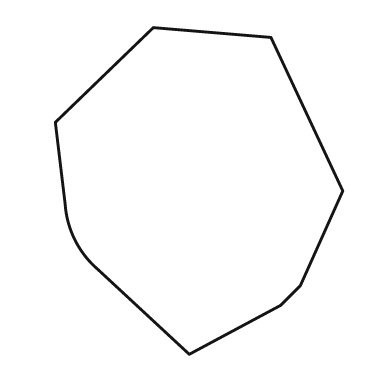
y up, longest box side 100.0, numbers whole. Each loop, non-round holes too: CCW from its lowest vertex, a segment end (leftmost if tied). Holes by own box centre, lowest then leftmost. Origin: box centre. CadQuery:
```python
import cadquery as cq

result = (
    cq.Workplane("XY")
    .moveTo(-3.0, -50.0)
    .lineTo(25.0, -35.0)
    .lineTo(31.0, -29.0)
    .lineTo(44.0, 0.0)
    .lineTo(22.0, 47.0)
    .lineTo(-14.0, 50.0)
    .lineTo(-44.0, 21.0)
    .lineTo(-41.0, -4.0)
    .threePointArc((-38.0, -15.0), (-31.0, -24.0))
    .close()
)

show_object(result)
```